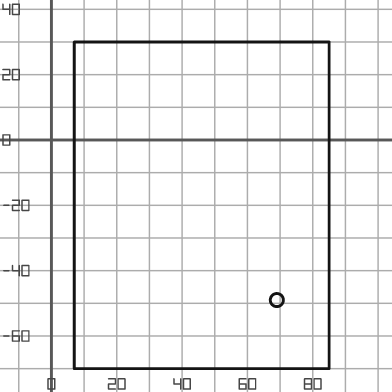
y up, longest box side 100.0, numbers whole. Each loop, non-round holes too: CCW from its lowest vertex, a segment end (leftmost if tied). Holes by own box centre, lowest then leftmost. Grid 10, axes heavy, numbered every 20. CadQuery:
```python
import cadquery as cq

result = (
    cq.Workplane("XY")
    .moveTo(7.0, -70.0)
    .lineTo(85.0, -70.0)
    .lineTo(85.0, 30.0)
    .lineTo(7.0, 30.0)
    .close()
    .moveTo(69.0, -49.0)
    .circle(2.0)
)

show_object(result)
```